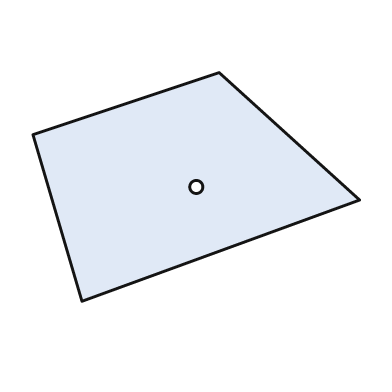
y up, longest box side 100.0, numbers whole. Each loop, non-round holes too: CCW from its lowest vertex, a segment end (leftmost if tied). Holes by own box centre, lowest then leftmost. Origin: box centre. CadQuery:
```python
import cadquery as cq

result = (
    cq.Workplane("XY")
    .moveTo(-35.0, -35.0)
    .lineTo(50.0, -4.0)
    .lineTo(7.0, 35.0)
    .lineTo(-50.0, 16.0)
    .close()
    .moveTo(0.0, 0.0)
    .circle(2.0)
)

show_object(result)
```